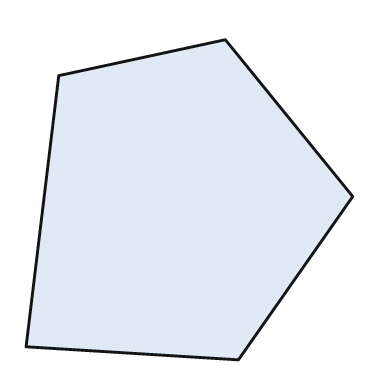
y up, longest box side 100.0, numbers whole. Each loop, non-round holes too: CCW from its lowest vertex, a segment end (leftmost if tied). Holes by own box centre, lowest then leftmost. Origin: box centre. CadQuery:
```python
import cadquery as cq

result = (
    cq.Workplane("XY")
    .moveTo(15.0, -49.0)
    .lineTo(50.0, 1.0)
    .lineTo(11.0, 49.0)
    .lineTo(-40.0, 38.0)
    .lineTo(-50.0, -45.0)
    .close()
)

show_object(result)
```